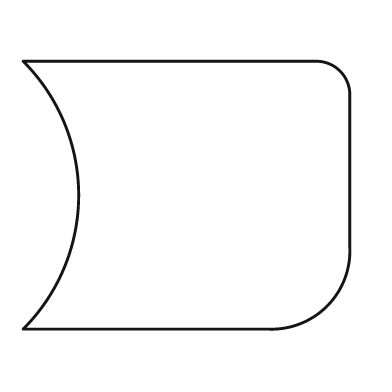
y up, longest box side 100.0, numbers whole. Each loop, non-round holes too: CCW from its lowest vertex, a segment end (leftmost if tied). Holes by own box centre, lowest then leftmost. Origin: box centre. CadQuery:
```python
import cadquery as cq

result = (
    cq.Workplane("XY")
    .moveTo(-50.0, -41.0)
    .lineTo(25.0, -41.0)
    .threePointArc((43.0, -34.0), (50.0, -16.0))
    .lineTo(50.0, 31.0)
    .threePointArc((47.0, 38.0), (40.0, 41.0))
    .lineTo(-50.0, 41.0)
    .threePointArc((-33.0, 0.0), (-50.0, -41.0))
    .close()
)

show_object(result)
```